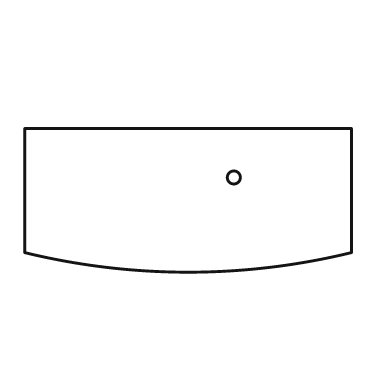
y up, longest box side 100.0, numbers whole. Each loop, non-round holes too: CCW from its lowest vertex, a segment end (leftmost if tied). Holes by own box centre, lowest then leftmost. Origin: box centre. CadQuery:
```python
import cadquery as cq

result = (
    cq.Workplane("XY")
    .moveTo(-50.0, -16.0)
    .threePointArc((0.0, -22.0), (50.0, -16.0))
    .lineTo(50.0, 22.0)
    .lineTo(-50.0, 22.0)
    .close()
    .moveTo(14.0, 7.0)
    .circle(2.0)
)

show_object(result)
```